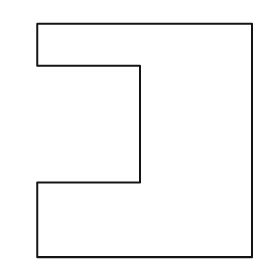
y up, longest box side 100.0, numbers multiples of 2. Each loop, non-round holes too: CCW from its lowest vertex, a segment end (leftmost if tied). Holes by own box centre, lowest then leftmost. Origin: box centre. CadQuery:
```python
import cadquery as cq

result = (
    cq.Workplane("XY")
    .moveTo(-46.0, -50.0)
    .lineTo(46.0, -50.0)
    .lineTo(46.0, 50.0)
    .lineTo(-46.0, 50.0)
    .lineTo(-46.0, 32.0)
    .lineTo(-2.0, 32.0)
    .lineTo(-2.0, -18.0)
    .lineTo(-46.0, -18.0)
    .close()
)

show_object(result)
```